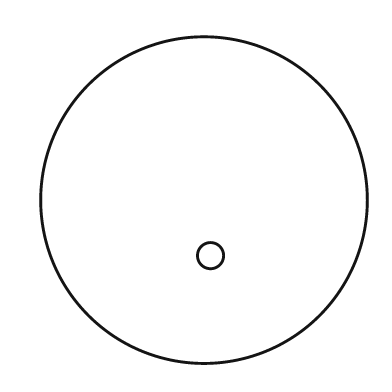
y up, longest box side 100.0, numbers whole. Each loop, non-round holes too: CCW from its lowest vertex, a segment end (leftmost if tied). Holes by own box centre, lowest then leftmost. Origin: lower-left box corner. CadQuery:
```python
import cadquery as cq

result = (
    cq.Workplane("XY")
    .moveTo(50.0, 50.0)
    .circle(50.0)
    .moveTo(52.0, 33.0)
    .circle(4.0)
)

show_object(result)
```